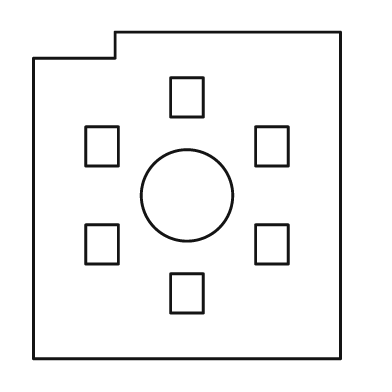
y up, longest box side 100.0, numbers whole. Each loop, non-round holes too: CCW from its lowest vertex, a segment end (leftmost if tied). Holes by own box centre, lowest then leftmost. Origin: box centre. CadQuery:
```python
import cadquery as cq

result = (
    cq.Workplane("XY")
    .moveTo(-47.0, -50.0)
    .lineTo(47.0, -50.0)
    .lineTo(47.0, 50.0)
    .lineTo(-22.0, 50.0)
    .lineTo(-22.0, 42.0)
    .lineTo(-47.0, 42.0)
    .close()
    .moveTo(-5.0, -36.0)
    .lineTo(5.0, -36.0)
    .lineTo(5.0, -24.0)
    .lineTo(-5.0, -24.0)
    .close()
    .moveTo(-31.0, -21.0)
    .lineTo(-21.0, -21.0)
    .lineTo(-21.0, -9.0)
    .lineTo(-31.0, -9.0)
    .close()
    .moveTo(21.0, -21.0)
    .lineTo(31.0, -21.0)
    .lineTo(31.0, -9.0)
    .lineTo(21.0, -9.0)
    .close()
    .moveTo(0.0, 0.0)
    .circle(14.0)
    .moveTo(-31.0, 9.0)
    .lineTo(-21.0, 9.0)
    .lineTo(-21.0, 21.0)
    .lineTo(-31.0, 21.0)
    .close()
    .moveTo(21.0, 9.0)
    .lineTo(31.0, 9.0)
    .lineTo(31.0, 21.0)
    .lineTo(21.0, 21.0)
    .close()
    .moveTo(-5.0, 24.0)
    .lineTo(5.0, 24.0)
    .lineTo(5.0, 36.0)
    .lineTo(-5.0, 36.0)
    .close()
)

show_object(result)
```